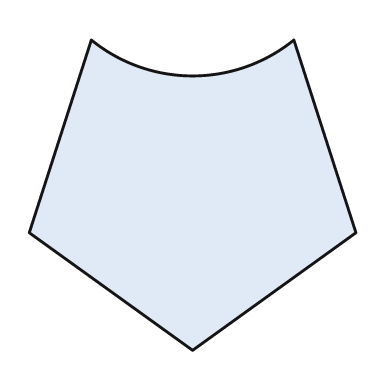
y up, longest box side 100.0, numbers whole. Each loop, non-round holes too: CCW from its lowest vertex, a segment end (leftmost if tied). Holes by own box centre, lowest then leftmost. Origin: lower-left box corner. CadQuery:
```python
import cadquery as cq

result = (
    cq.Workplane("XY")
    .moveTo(50.0, 0.0)
    .lineTo(100.0, 36.0)
    .lineTo(81.0, 95.0)
    .threePointArc((50.0, 84.0), (19.0, 95.0))
    .lineTo(0.0, 36.0)
    .close()
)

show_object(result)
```